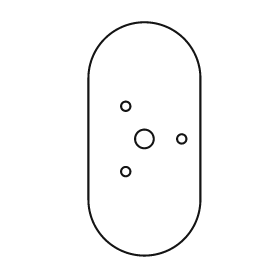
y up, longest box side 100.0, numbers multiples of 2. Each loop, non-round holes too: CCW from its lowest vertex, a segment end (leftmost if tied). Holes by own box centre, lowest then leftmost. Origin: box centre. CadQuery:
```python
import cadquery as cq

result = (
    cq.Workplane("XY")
    .moveTo(-24.0, -26.0)
    .threePointArc((0.0, -50.0), (24.0, -26.0))
    .lineTo(24.0, 26.0)
    .threePointArc((0.0, 50.0), (-24.0, 26.0))
    .close()
    .moveTo(-8.0, -14.0)
    .circle(2.0)
    .moveTo(0.0, 0.0)
    .circle(4.0)
    .moveTo(16.0, 0.0)
    .circle(2.0)
    .moveTo(-8.0, 14.0)
    .circle(2.0)
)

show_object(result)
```